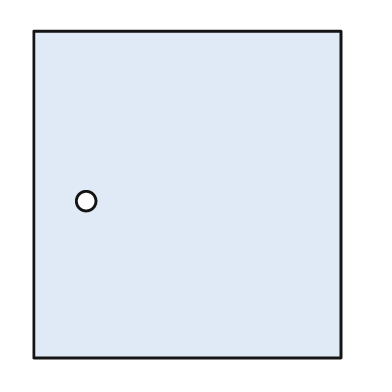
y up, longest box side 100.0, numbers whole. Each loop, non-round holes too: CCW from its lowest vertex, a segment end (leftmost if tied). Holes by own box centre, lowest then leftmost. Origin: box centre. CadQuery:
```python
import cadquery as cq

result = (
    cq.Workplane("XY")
    .moveTo(-47.0, -50.0)
    .lineTo(47.0, -50.0)
    .lineTo(47.0, 50.0)
    .lineTo(-47.0, 50.0)
    .close()
    .moveTo(-31.0, -2.0)
    .circle(3.0)
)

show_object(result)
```